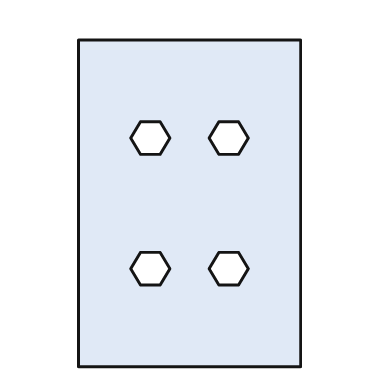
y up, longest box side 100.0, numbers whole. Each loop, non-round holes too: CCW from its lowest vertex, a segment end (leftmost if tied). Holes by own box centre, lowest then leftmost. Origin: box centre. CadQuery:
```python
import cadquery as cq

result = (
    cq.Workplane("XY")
    .moveTo(-34.0, -50.0)
    .lineTo(34.0, -50.0)
    .lineTo(34.0, 50.0)
    .lineTo(-34.0, 50.0)
    .close()
    .moveTo(-15.0, -25.0)
    .lineTo(-9.0, -25.0)
    .lineTo(-6.0, -20.0)
    .lineTo(-9.0, -15.0)
    .lineTo(-15.0, -15.0)
    .lineTo(-18.0, -20.0)
    .close()
    .moveTo(9.0, -25.0)
    .lineTo(15.0, -25.0)
    .lineTo(18.0, -20.0)
    .lineTo(15.0, -15.0)
    .lineTo(9.0, -15.0)
    .lineTo(6.0, -20.0)
    .close()
    .moveTo(-15.0, 15.0)
    .lineTo(-9.0, 15.0)
    .lineTo(-6.0, 20.0)
    .lineTo(-9.0, 25.0)
    .lineTo(-15.0, 25.0)
    .lineTo(-18.0, 20.0)
    .close()
    .moveTo(9.0, 15.0)
    .lineTo(15.0, 15.0)
    .lineTo(18.0, 20.0)
    .lineTo(15.0, 25.0)
    .lineTo(9.0, 25.0)
    .lineTo(6.0, 20.0)
    .close()
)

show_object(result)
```